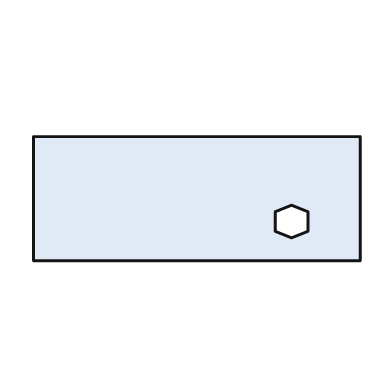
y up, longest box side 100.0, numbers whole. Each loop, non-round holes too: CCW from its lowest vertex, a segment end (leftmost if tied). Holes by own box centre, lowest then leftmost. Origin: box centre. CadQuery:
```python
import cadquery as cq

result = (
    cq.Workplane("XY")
    .moveTo(-50.0, -19.0)
    .lineTo(50.0, -19.0)
    .lineTo(50.0, 19.0)
    .lineTo(-50.0, 19.0)
    .close()
    .moveTo(29.0, -12.0)
    .lineTo(34.0, -10.0)
    .lineTo(34.0, -4.0)
    .lineTo(29.0, -2.0)
    .lineTo(24.0, -4.0)
    .lineTo(24.0, -10.0)
    .close()
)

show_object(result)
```